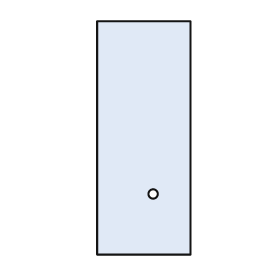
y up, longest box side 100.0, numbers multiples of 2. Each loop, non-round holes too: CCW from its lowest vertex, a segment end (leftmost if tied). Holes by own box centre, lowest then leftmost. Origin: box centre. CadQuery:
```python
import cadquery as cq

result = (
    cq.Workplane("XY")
    .moveTo(-20.0, -50.0)
    .lineTo(20.0, -50.0)
    .lineTo(20.0, 50.0)
    .lineTo(-20.0, 50.0)
    .close()
    .moveTo(4.0, -24.0)
    .circle(2.0)
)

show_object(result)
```